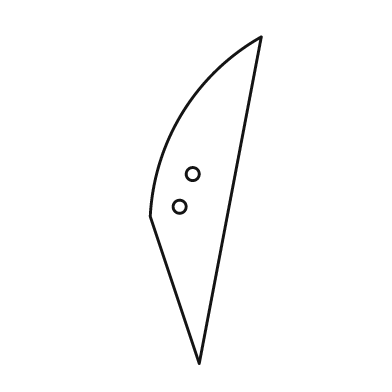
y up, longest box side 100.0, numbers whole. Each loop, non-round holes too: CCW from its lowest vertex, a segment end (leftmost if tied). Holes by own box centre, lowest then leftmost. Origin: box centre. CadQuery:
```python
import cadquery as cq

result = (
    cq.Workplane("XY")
    .moveTo(-2.0, -50.0)
    .lineTo(17.0, 50.0)
    .threePointArc((-7.0, 27.0), (-17.0, -5.0))
    .close()
    .moveTo(-8.0, -2.0)
    .circle(2.0)
    .moveTo(-4.0, 8.0)
    .circle(2.0)
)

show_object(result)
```